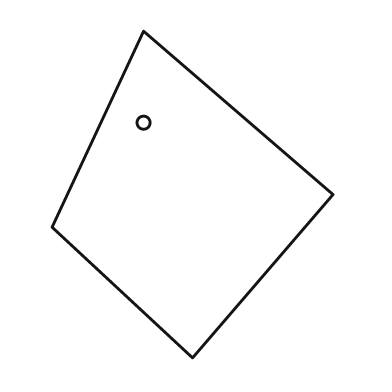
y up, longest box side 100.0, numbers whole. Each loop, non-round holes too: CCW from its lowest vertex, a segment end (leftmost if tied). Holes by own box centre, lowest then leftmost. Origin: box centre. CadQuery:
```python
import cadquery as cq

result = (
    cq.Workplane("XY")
    .moveTo(0.0, -50.0)
    .lineTo(43.0, 0.0)
    .lineTo(-15.0, 50.0)
    .lineTo(-43.0, -10.0)
    .close()
    .moveTo(-15.0, 22.0)
    .circle(2.0)
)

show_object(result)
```